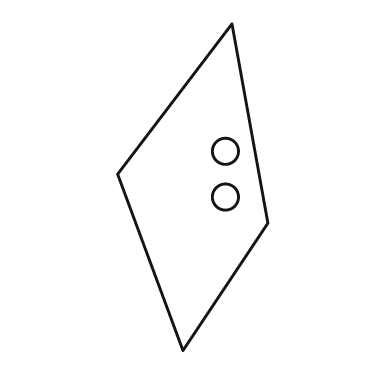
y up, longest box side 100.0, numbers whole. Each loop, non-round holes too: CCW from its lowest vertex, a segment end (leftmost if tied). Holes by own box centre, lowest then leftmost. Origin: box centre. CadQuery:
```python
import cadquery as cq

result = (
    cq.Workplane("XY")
    .moveTo(-3.0, -50.0)
    .lineTo(23.0, -11.0)
    .lineTo(12.0, 50.0)
    .lineTo(-23.0, 4.0)
    .close()
    .moveTo(10.0, -3.0)
    .circle(4.0)
    .moveTo(10.0, 11.0)
    .circle(4.0)
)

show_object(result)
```